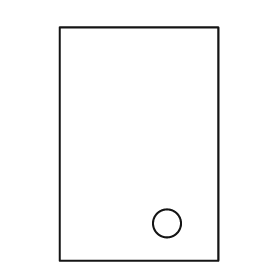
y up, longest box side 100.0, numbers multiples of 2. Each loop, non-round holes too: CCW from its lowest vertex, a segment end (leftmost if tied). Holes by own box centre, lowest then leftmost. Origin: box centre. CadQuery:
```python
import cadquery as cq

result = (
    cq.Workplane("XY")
    .moveTo(-34.0, -50.0)
    .lineTo(34.0, -50.0)
    .lineTo(34.0, 50.0)
    .lineTo(-34.0, 50.0)
    .close()
    .moveTo(12.0, -34.0)
    .circle(6.0)
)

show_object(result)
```